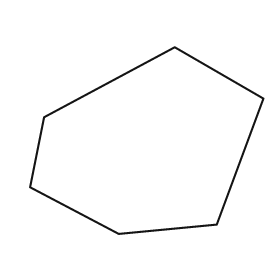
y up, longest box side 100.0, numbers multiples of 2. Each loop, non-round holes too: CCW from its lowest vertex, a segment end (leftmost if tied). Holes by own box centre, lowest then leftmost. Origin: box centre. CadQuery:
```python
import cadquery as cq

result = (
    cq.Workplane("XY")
    .moveTo(-12.0, -40.0)
    .lineTo(30.0, -36.0)
    .lineTo(50.0, 18.0)
    .lineTo(12.0, 40.0)
    .lineTo(-44.0, 10.0)
    .lineTo(-50.0, -20.0)
    .close()
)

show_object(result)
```